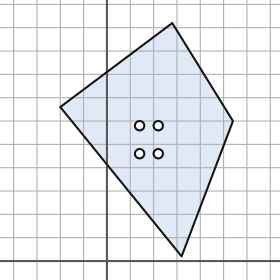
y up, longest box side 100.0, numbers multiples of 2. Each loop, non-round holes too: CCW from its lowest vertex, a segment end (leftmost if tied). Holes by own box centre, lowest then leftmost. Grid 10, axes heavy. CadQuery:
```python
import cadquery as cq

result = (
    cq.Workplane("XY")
    .moveTo(32.0, 2.0)
    .lineTo(54.0, 60.0)
    .lineTo(28.0, 102.0)
    .lineTo(-20.0, 66.0)
    .close()
    .moveTo(14.0, 46.0)
    .circle(2.0)
    .moveTo(22.0, 46.0)
    .circle(2.0)
    .moveTo(14.0, 58.0)
    .circle(2.0)
    .moveTo(22.0, 58.0)
    .circle(2.0)
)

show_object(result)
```